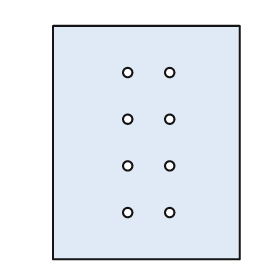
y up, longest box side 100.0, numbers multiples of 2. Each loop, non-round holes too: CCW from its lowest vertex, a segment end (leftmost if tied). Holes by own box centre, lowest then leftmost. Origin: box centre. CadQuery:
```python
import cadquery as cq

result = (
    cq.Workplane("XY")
    .moveTo(-40.0, -50.0)
    .lineTo(40.0, -50.0)
    .lineTo(40.0, 50.0)
    .lineTo(-40.0, 50.0)
    .close()
    .moveTo(-8.0, -30.0)
    .circle(2.0)
    .moveTo(10.0, -30.0)
    .circle(2.0)
    .moveTo(-8.0, -10.0)
    .circle(2.0)
    .moveTo(10.0, -10.0)
    .circle(2.0)
    .moveTo(-8.0, 10.0)
    .circle(2.0)
    .moveTo(10.0, 10.0)
    .circle(2.0)
    .moveTo(-8.0, 30.0)
    .circle(2.0)
    .moveTo(10.0, 30.0)
    .circle(2.0)
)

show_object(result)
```